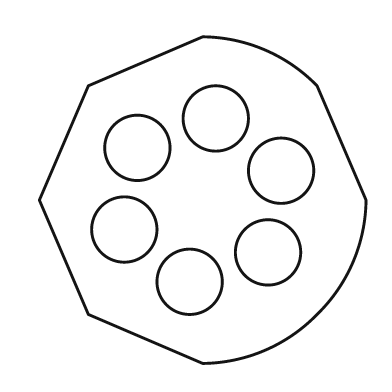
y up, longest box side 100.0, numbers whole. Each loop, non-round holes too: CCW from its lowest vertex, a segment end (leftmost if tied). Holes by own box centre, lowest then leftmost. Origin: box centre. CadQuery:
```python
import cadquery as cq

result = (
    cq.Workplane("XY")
    .moveTo(0.0, -50.0)
    .threePointArc((19.0, -46.0), (35.0, -35.0))
    .threePointArc((46.0, -19.0), (50.0, 0.0))
    .lineTo(35.0, 35.0)
    .threePointArc((19.0, 46.0), (0.0, 50.0))
    .lineTo(-35.0, 35.0)
    .lineTo(-50.0, 0.0)
    .lineTo(-35.0, -35.0)
    .close()
    .moveTo(-4.0, -25.0)
    .circle(10.0)
    .moveTo(20.0, -16.0)
    .circle(10.0)
    .moveTo(-24.0, -9.0)
    .circle(10.0)
    .moveTo(24.0, 9.0)
    .circle(10.0)
    .moveTo(-20.0, 16.0)
    .circle(10.0)
    .moveTo(4.0, 25.0)
    .circle(10.0)
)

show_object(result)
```